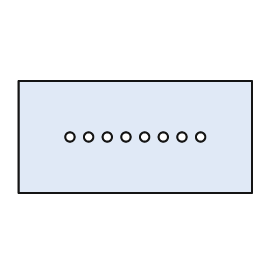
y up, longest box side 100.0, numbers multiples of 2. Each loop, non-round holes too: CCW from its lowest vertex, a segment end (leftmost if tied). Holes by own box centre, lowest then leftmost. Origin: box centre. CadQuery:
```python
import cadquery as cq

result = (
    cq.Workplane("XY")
    .moveTo(-50.0, -24.0)
    .lineTo(50.0, -24.0)
    .lineTo(50.0, 24.0)
    .lineTo(-50.0, 24.0)
    .close()
    .moveTo(-28.0, 0.0)
    .circle(2.0)
    .moveTo(-20.0, 0.0)
    .circle(2.0)
    .moveTo(-12.0, 0.0)
    .circle(2.0)
    .moveTo(-4.0, 0.0)
    .circle(2.0)
    .moveTo(4.0, 0.0)
    .circle(2.0)
    .moveTo(12.0, 0.0)
    .circle(2.0)
    .moveTo(20.0, 0.0)
    .circle(2.0)
    .moveTo(28.0, 0.0)
    .circle(2.0)
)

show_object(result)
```